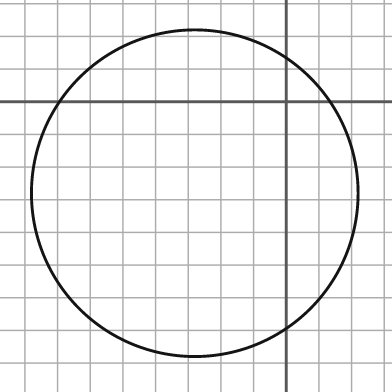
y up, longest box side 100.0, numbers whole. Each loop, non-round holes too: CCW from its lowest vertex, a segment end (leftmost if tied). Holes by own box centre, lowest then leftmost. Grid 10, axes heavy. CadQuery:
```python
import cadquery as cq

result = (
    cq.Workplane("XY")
    .moveTo(-28.0, -28.0)
    .circle(50.0)
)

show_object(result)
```